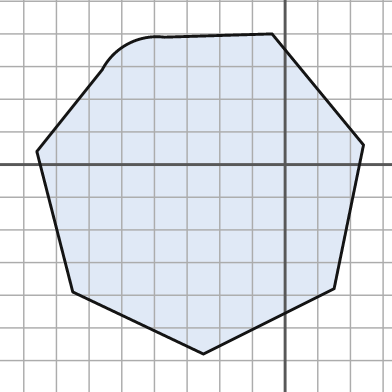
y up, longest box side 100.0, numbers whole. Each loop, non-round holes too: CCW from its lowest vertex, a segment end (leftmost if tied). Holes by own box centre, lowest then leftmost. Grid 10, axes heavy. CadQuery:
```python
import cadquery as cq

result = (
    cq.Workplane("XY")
    .moveTo(-25.0, -58.0)
    .lineTo(15.0, -38.0)
    .lineTo(24.0, 6.0)
    .lineTo(-4.0, 40.0)
    .lineTo(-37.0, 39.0)
    .threePointArc((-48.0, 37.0), (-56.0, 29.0))
    .lineTo(-76.0, 4.0)
    .lineTo(-65.0, -39.0)
    .close()
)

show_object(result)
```